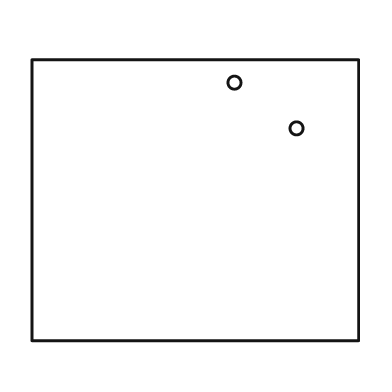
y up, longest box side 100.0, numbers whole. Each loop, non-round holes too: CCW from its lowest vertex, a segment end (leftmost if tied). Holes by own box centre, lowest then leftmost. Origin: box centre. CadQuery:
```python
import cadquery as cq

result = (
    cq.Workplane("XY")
    .moveTo(-50.0, -43.0)
    .lineTo(50.0, -43.0)
    .lineTo(50.0, 43.0)
    .lineTo(-50.0, 43.0)
    .close()
    .moveTo(31.0, 22.0)
    .circle(2.0)
    .moveTo(12.0, 36.0)
    .circle(2.0)
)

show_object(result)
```